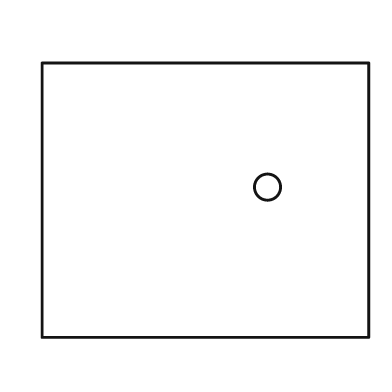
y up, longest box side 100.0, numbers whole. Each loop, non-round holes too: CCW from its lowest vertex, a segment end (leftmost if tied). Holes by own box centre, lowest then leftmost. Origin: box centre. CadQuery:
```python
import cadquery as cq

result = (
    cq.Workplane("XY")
    .moveTo(-50.0, -42.0)
    .lineTo(50.0, -42.0)
    .lineTo(50.0, 42.0)
    .lineTo(-50.0, 42.0)
    .close()
    .moveTo(19.0, 4.0)
    .circle(4.0)
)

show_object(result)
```